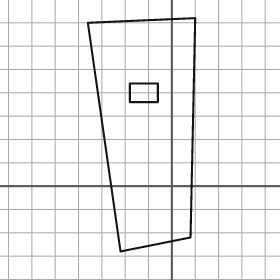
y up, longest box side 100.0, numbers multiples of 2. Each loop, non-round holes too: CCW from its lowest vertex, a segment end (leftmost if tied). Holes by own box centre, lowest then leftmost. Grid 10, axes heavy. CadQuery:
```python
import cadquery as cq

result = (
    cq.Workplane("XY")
    .moveTo(-22.0, -28.0)
    .lineTo(8.0, -22.0)
    .lineTo(10.0, 72.0)
    .lineTo(-36.0, 70.0)
    .close()
    .moveTo(-18.0, 36.0)
    .lineTo(-6.0, 36.0)
    .lineTo(-6.0, 44.0)
    .lineTo(-18.0, 44.0)
    .close()
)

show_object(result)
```